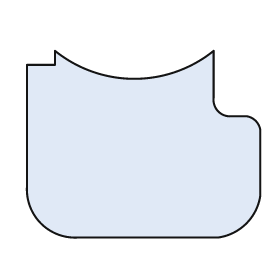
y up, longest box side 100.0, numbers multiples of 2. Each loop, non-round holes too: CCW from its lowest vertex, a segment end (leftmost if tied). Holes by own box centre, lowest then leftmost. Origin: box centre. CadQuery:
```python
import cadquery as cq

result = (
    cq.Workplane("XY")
    .moveTo(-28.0, -40.0)
    .lineTo(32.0, -40.0)
    .threePointArc((44.0, -34.0), (50.0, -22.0))
    .lineTo(50.0, 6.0)
    .threePointArc((48.0, 10.0), (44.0, 12.0))
    .lineTo(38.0, 12.0)
    .threePointArc((32.0, 14.0), (30.0, 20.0))
    .lineTo(30.0, 40.0)
    .threePointArc((-4.0, 28.0), (-38.0, 40.0))
    .lineTo(-38.0, 34.0)
    .lineTo(-50.0, 34.0)
    .lineTo(-50.0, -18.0)
    .threePointArc((-44.0, -34.0), (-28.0, -40.0))
    .close()
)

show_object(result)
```